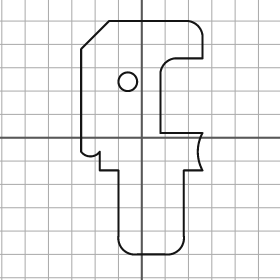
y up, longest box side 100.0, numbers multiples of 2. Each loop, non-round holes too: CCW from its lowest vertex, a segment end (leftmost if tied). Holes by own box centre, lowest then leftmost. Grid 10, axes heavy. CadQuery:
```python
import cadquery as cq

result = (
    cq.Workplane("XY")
    .moveTo(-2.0, -50.0)
    .lineTo(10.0, -50.0)
    .threePointArc((16.0, -48.0), (18.0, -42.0))
    .lineTo(18.0, -14.0)
    .lineTo(26.0, -14.0)
    .threePointArc((24.0, -6.0), (26.0, 2.0))
    .lineTo(8.0, 2.0)
    .lineTo(8.0, 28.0)
    .threePointArc((10.0, 32.0), (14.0, 34.0))
    .lineTo(26.0, 34.0)
    .lineTo(26.0, 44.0)
    .threePointArc((24.0, 48.0), (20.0, 50.0))
    .lineTo(-14.0, 50.0)
    .lineTo(-26.0, 38.0)
    .lineTo(-26.0, -6.0)
    .threePointArc((-22.0, -8.0), (-18.0, -6.0))
    .lineTo(-18.0, -14.0)
    .lineTo(-10.0, -14.0)
    .lineTo(-10.0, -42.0)
    .threePointArc((-8.0, -48.0), (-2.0, -50.0))
    .close()
    .moveTo(-6.0, 24.0)
    .circle(4.0)
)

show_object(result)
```